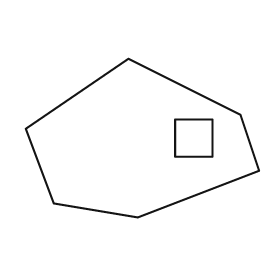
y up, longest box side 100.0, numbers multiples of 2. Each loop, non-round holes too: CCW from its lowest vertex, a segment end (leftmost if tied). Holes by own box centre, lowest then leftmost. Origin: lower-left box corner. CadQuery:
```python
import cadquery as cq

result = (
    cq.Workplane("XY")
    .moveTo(48.0, 0.0)
    .lineTo(100.0, 20.0)
    .lineTo(92.0, 44.0)
    .lineTo(44.0, 68.0)
    .lineTo(0.0, 38.0)
    .lineTo(12.0, 6.0)
    .close()
    .moveTo(64.0, 26.0)
    .lineTo(80.0, 26.0)
    .lineTo(80.0, 42.0)
    .lineTo(64.0, 42.0)
    .close()
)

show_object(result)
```